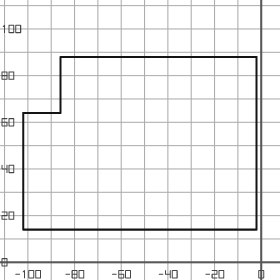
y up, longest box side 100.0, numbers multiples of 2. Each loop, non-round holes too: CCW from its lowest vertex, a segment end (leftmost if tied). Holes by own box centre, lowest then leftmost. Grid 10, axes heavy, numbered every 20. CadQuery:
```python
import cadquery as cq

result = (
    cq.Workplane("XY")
    .moveTo(-102.0, 14.0)
    .lineTo(-2.0, 14.0)
    .lineTo(-2.0, 88.0)
    .lineTo(-86.0, 88.0)
    .lineTo(-86.0, 64.0)
    .lineTo(-102.0, 64.0)
    .close()
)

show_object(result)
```